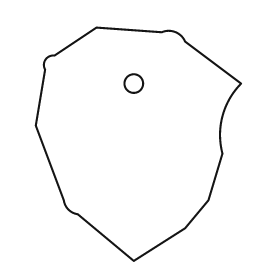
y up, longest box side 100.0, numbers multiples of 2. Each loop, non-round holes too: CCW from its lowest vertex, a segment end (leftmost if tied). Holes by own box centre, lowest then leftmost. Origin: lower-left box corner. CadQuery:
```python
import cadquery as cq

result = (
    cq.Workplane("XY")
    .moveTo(42.0, 0.0)
    .lineTo(64.0, 14.0)
    .lineTo(74.0, 26.0)
    .lineTo(80.0, 46.0)
    .threePointArc((80.0, 62.0), (88.0, 76.0))
    .lineTo(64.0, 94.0)
    .threePointArc((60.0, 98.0), (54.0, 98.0))
    .lineTo(26.0, 100.0)
    .lineTo(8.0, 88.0)
    .threePointArc((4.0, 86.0), (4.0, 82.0))
    .lineTo(0.0, 58.0)
    .lineTo(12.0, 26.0)
    .threePointArc((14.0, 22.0), (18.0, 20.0))
    .close()
    .moveTo(42.0, 76.0)
    .circle(4.0)
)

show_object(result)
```